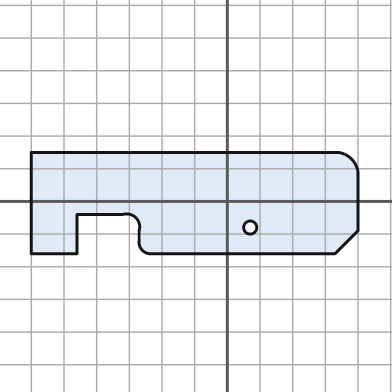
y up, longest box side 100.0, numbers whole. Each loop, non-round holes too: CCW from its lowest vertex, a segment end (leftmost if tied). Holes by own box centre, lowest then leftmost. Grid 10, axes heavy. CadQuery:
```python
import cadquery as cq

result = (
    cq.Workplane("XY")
    .moveTo(-60.0, -16.0)
    .lineTo(-46.0, -16.0)
    .lineTo(-46.0, -4.0)
    .lineTo(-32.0, -4.0)
    .threePointArc((-28.0, -5.0), (-27.0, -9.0))
    .lineTo(-27.0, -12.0)
    .threePointArc((-26.0, -15.0), (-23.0, -16.0))
    .lineTo(33.0, -16.0)
    .lineTo(40.0, -9.0)
    .lineTo(40.0, 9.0)
    .threePointArc((38.0, 13.0), (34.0, 15.0))
    .lineTo(-60.0, 15.0)
    .close()
    .moveTo(7.0, -8.0)
    .circle(2.0)
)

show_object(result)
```